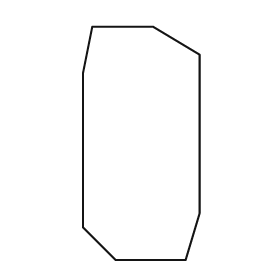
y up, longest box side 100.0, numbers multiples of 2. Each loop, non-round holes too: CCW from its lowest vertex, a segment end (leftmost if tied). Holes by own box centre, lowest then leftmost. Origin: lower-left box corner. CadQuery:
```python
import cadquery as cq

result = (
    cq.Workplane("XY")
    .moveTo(14.0, 0.0)
    .lineTo(44.0, 0.0)
    .lineTo(50.0, 20.0)
    .lineTo(50.0, 88.0)
    .lineTo(30.0, 100.0)
    .lineTo(4.0, 100.0)
    .lineTo(0.0, 80.0)
    .lineTo(0.0, 14.0)
    .close()
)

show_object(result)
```